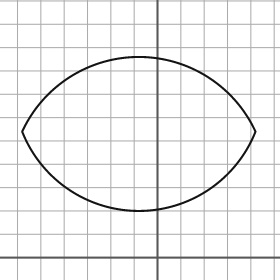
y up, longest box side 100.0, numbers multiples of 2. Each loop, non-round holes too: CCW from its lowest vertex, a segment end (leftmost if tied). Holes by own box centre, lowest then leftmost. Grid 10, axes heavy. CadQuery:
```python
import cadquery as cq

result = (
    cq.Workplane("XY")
    .moveTo(-58.0, 54.0)
    .threePointArc((-8.0, 20.0), (42.0, 54.0))
    .threePointArc((-8.0, 86.0), (-58.0, 54.0))
    .close()
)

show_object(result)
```